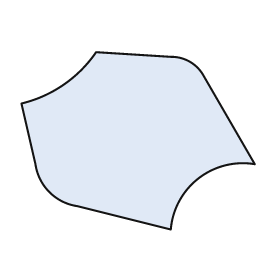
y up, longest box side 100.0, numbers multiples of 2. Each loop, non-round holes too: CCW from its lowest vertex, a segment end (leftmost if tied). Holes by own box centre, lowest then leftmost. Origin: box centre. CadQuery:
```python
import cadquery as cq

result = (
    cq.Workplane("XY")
    .moveTo(14.0, -38.0)
    .threePointArc((26.0, -16.0), (50.0, -10.0))
    .lineTo(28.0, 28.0)
    .threePointArc((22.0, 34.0), (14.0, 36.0))
    .lineTo(-18.0, 38.0)
    .threePointArc((-32.0, 24.0), (-50.0, 16.0))
    .lineTo(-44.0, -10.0)
    .threePointArc((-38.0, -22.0), (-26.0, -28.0))
    .close()
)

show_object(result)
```